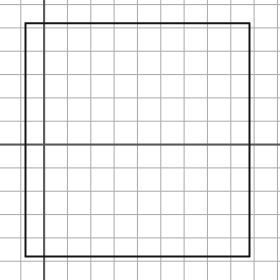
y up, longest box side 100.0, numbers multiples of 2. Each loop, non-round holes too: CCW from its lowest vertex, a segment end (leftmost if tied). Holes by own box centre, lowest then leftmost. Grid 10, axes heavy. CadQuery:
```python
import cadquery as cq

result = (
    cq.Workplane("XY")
    .moveTo(-8.0, -48.0)
    .lineTo(88.0, -48.0)
    .lineTo(88.0, 52.0)
    .lineTo(-8.0, 52.0)
    .close()
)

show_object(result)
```